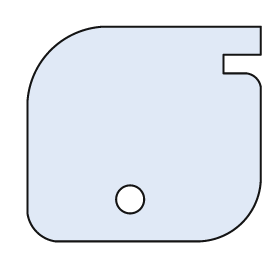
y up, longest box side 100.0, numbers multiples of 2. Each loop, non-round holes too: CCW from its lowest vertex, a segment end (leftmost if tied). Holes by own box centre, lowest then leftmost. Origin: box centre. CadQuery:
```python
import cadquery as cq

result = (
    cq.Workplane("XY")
    .moveTo(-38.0, -46.0)
    .lineTo(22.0, -46.0)
    .threePointArc((42.0, -38.0), (50.0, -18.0))
    .lineTo(50.0, 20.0)
    .threePointArc((48.0, 24.0), (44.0, 26.0))
    .lineTo(34.0, 26.0)
    .lineTo(34.0, 34.0)
    .lineTo(50.0, 34.0)
    .lineTo(50.0, 46.0)
    .lineTo(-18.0, 46.0)
    .threePointArc((-40.0, 36.0), (-50.0, 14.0))
    .lineTo(-50.0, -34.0)
    .threePointArc((-46.0, -42.0), (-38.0, -46.0))
    .close()
    .moveTo(-6.0, -28.0)
    .circle(6.0)
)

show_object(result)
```